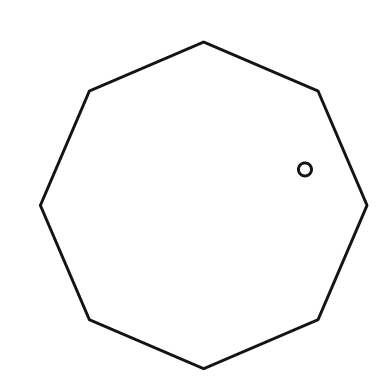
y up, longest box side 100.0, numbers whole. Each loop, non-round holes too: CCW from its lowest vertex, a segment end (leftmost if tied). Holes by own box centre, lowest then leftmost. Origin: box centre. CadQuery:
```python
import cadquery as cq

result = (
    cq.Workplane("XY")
    .moveTo(0.0, -50.0)
    .lineTo(35.0, -35.0)
    .lineTo(50.0, 0.0)
    .lineTo(35.0, 35.0)
    .lineTo(0.0, 50.0)
    .lineTo(-35.0, 35.0)
    .lineTo(-50.0, 0.0)
    .lineTo(-35.0, -35.0)
    .close()
    .moveTo(31.0, 11.0)
    .circle(2.0)
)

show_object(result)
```